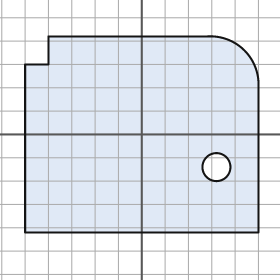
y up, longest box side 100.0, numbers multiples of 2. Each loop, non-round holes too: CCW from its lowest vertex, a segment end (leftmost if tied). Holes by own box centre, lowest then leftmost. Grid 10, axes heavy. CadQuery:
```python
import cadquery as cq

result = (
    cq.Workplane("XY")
    .moveTo(-50.0, -42.0)
    .lineTo(50.0, -42.0)
    .lineTo(50.0, 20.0)
    .threePointArc((44.0, 36.0), (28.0, 42.0))
    .lineTo(-40.0, 42.0)
    .lineTo(-40.0, 30.0)
    .lineTo(-50.0, 30.0)
    .close()
    .moveTo(32.0, -14.0)
    .circle(6.0)
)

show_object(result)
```